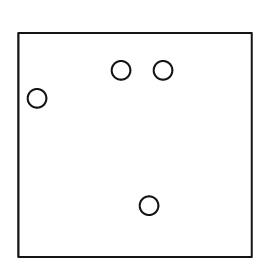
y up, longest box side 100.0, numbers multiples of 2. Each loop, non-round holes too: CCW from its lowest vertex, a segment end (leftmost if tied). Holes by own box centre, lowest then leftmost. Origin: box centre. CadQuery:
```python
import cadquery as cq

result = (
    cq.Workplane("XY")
    .moveTo(-50.0, -48.0)
    .lineTo(50.0, -48.0)
    .lineTo(50.0, 48.0)
    .lineTo(-50.0, 48.0)
    .close()
    .moveTo(6.0, -26.0)
    .circle(4.0)
    .moveTo(-42.0, 20.0)
    .circle(4.0)
    .moveTo(-6.0, 32.0)
    .circle(4.0)
    .moveTo(12.0, 32.0)
    .circle(4.0)
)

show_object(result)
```